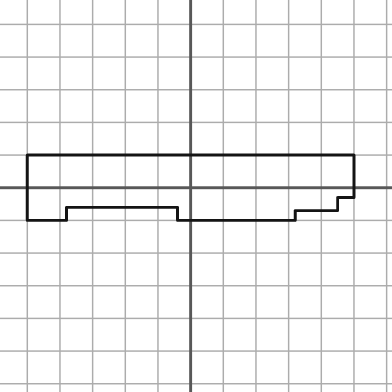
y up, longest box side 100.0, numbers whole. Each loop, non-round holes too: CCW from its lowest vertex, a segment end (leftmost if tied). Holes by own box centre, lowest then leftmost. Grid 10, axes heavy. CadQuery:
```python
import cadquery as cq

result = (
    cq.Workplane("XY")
    .moveTo(-50.0, -10.0)
    .lineTo(-38.0, -10.0)
    .lineTo(-38.0, -6.0)
    .lineTo(-4.0, -6.0)
    .lineTo(-4.0, -10.0)
    .lineTo(32.0, -10.0)
    .lineTo(32.0, -7.0)
    .lineTo(45.0, -7.0)
    .lineTo(45.0, -3.0)
    .lineTo(50.0, -3.0)
    .lineTo(50.0, 10.0)
    .lineTo(-50.0, 10.0)
    .close()
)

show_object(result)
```